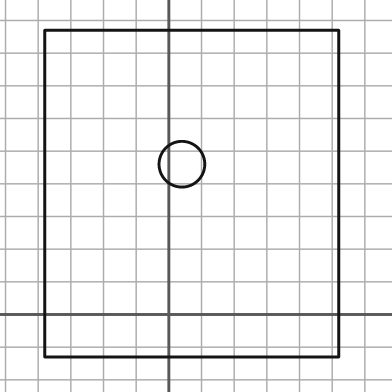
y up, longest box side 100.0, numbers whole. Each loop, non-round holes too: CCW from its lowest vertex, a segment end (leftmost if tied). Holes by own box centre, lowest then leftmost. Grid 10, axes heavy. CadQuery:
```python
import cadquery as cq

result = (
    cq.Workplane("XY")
    .moveTo(-38.0, -13.0)
    .lineTo(52.0, -13.0)
    .lineTo(52.0, 87.0)
    .lineTo(-38.0, 87.0)
    .close()
    .moveTo(4.0, 46.0)
    .circle(7.0)
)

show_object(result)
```